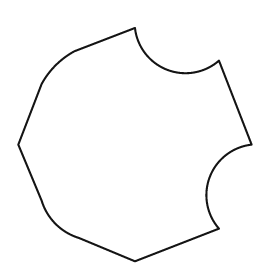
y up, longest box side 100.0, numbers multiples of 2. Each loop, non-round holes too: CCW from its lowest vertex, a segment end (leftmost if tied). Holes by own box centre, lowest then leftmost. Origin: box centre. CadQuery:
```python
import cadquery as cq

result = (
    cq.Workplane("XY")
    .moveTo(0.0, -50.0)
    .lineTo(36.0, -36.0)
    .threePointArc((32.0, -14.0), (50.0, 0.0))
    .lineTo(36.0, 36.0)
    .threePointArc((14.0, 32.0), (0.0, 50.0))
    .lineTo(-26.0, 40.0)
    .threePointArc((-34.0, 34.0), (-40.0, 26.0))
    .lineTo(-50.0, 0.0)
    .lineTo(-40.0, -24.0)
    .threePointArc((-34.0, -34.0), (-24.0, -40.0))
    .close()
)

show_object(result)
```